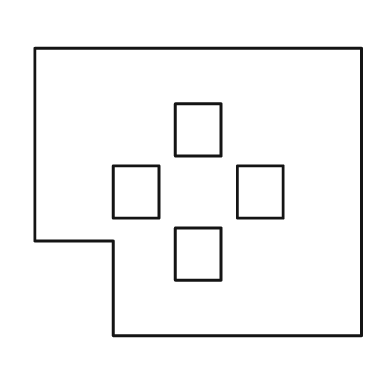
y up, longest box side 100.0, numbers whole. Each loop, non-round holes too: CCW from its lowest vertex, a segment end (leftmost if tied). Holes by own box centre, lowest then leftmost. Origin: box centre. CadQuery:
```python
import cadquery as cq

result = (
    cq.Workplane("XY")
    .moveTo(-26.0, -44.0)
    .lineTo(50.0, -44.0)
    .lineTo(50.0, 44.0)
    .lineTo(-50.0, 44.0)
    .lineTo(-50.0, -15.0)
    .lineTo(-26.0, -15.0)
    .close()
    .moveTo(-7.0, -27.0)
    .lineTo(7.0, -27.0)
    .lineTo(7.0, -11.0)
    .lineTo(-7.0, -11.0)
    .close()
    .moveTo(-26.0, -8.0)
    .lineTo(-12.0, -8.0)
    .lineTo(-12.0, 8.0)
    .lineTo(-26.0, 8.0)
    .close()
    .moveTo(12.0, -8.0)
    .lineTo(26.0, -8.0)
    .lineTo(26.0, 8.0)
    .lineTo(12.0, 8.0)
    .close()
    .moveTo(-7.0, 11.0)
    .lineTo(7.0, 11.0)
    .lineTo(7.0, 27.0)
    .lineTo(-7.0, 27.0)
    .close()
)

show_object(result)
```